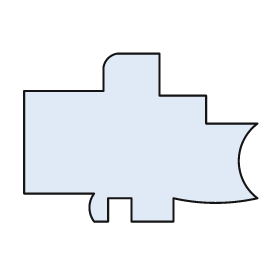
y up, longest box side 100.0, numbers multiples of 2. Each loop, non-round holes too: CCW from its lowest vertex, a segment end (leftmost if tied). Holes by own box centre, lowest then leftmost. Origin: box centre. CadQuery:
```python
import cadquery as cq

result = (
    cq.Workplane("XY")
    .moveTo(-20.0, -36.0)
    .lineTo(-14.0, -36.0)
    .lineTo(-14.0, -26.0)
    .lineTo(-4.0, -26.0)
    .lineTo(-4.0, -36.0)
    .lineTo(14.0, -36.0)
    .lineTo(14.0, -26.0)
    .threePointArc((32.0, -28.0), (50.0, -26.0))
    .threePointArc((42.0, -10.0), (50.0, 6.0))
    .lineTo(28.0, 6.0)
    .lineTo(28.0, 18.0)
    .lineTo(8.0, 18.0)
    .lineTo(8.0, 36.0)
    .lineTo(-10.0, 36.0)
    .threePointArc((-14.0, 34.0), (-16.0, 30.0))
    .lineTo(-16.0, 20.0)
    .lineTo(-50.0, 20.0)
    .lineTo(-50.0, -24.0)
    .lineTo(-20.0, -24.0)
    .threePointArc((-22.0, -30.0), (-20.0, -36.0))
    .close()
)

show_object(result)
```